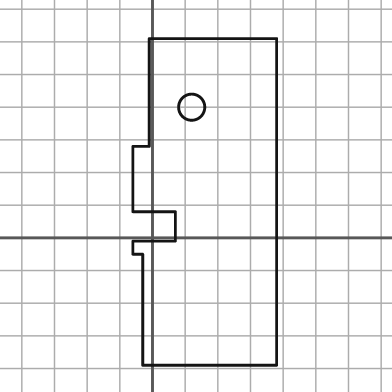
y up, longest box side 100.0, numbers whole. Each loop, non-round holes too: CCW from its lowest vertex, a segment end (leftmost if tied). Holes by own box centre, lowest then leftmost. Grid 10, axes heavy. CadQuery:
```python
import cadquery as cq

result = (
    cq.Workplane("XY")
    .moveTo(-3.0, -39.0)
    .lineTo(38.0, -39.0)
    .lineTo(38.0, 61.0)
    .lineTo(-1.0, 61.0)
    .lineTo(-1.0, 28.0)
    .lineTo(-6.0, 28.0)
    .lineTo(-6.0, 8.0)
    .lineTo(7.0, 8.0)
    .lineTo(7.0, -1.0)
    .lineTo(-6.0, -1.0)
    .lineTo(-6.0, -5.0)
    .lineTo(-3.0, -5.0)
    .close()
    .moveTo(12.0, 40.0)
    .circle(4.0)
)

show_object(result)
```